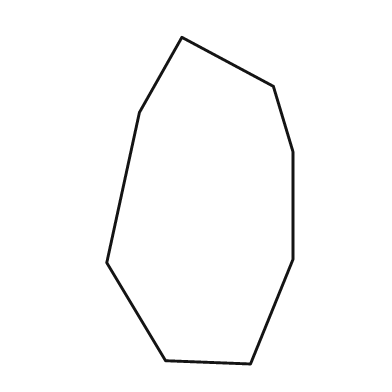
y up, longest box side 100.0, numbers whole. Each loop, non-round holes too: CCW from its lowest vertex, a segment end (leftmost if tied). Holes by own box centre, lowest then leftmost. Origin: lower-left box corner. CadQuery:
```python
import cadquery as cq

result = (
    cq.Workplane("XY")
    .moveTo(44.0, 0.0)
    .lineTo(57.0, 32.0)
    .lineTo(57.0, 65.0)
    .lineTo(51.0, 85.0)
    .lineTo(23.0, 100.0)
    .lineTo(10.0, 77.0)
    .lineTo(0.0, 31.0)
    .lineTo(18.0, 1.0)
    .close()
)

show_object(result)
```